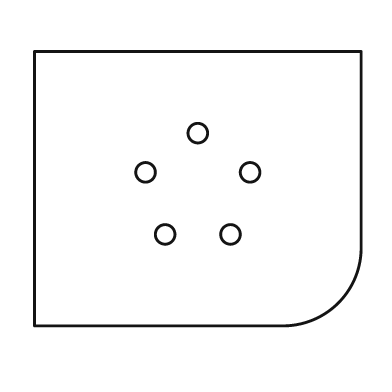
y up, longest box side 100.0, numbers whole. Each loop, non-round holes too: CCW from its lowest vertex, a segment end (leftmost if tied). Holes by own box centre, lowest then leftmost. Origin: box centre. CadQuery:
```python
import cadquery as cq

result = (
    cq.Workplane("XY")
    .moveTo(-50.0, -42.0)
    .lineTo(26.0, -42.0)
    .threePointArc((43.0, -35.0), (50.0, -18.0))
    .lineTo(50.0, 42.0)
    .lineTo(-50.0, 42.0)
    .close()
    .moveTo(-10.0, -14.0)
    .circle(3.0)
    .moveTo(10.0, -14.0)
    .circle(3.0)
    .moveTo(-16.0, 5.0)
    .circle(3.0)
    .moveTo(16.0, 5.0)
    .circle(3.0)
    .moveTo(0.0, 17.0)
    .circle(3.0)
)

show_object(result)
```